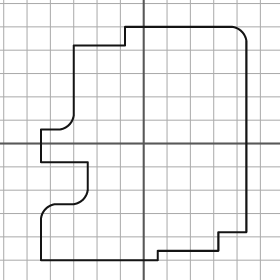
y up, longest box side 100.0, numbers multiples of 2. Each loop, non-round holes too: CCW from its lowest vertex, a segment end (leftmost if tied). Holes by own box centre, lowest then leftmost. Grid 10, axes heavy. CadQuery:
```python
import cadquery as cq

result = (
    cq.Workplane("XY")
    .moveTo(-44.0, -50.0)
    .lineTo(6.0, -50.0)
    .lineTo(6.0, -46.0)
    .lineTo(32.0, -46.0)
    .lineTo(32.0, -38.0)
    .lineTo(44.0, -38.0)
    .lineTo(44.0, 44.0)
    .threePointArc((42.0, 48.0), (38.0, 50.0))
    .lineTo(-8.0, 50.0)
    .lineTo(-8.0, 42.0)
    .lineTo(-30.0, 42.0)
    .lineTo(-30.0, 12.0)
    .threePointArc((-32.0, 8.0), (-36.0, 6.0))
    .lineTo(-44.0, 6.0)
    .lineTo(-44.0, -8.0)
    .lineTo(-24.0, -8.0)
    .lineTo(-24.0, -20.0)
    .threePointArc((-26.0, -24.0), (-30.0, -26.0))
    .lineTo(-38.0, -26.0)
    .threePointArc((-42.0, -28.0), (-44.0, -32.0))
    .close()
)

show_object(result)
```